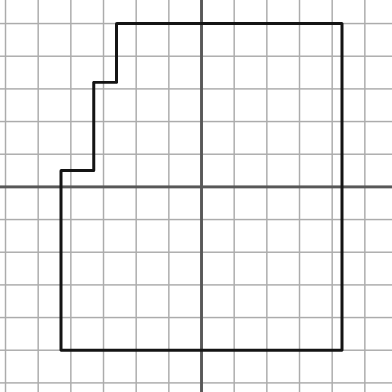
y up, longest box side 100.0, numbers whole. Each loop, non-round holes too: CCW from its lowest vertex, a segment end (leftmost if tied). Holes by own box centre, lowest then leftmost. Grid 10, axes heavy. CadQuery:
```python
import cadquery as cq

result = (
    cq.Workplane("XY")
    .moveTo(-43.0, -50.0)
    .lineTo(43.0, -50.0)
    .lineTo(43.0, 50.0)
    .lineTo(-26.0, 50.0)
    .lineTo(-26.0, 32.0)
    .lineTo(-33.0, 32.0)
    .lineTo(-33.0, 5.0)
    .lineTo(-43.0, 5.0)
    .close()
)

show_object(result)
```